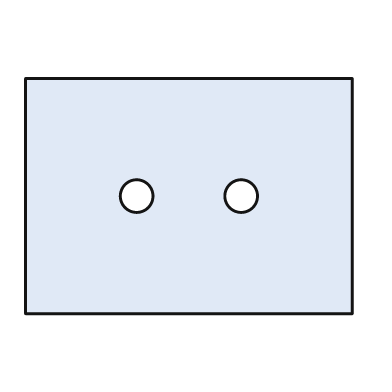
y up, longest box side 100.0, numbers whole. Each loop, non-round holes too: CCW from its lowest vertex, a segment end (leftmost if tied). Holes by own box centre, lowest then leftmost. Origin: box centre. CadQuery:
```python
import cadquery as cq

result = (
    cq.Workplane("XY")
    .moveTo(-50.0, -36.0)
    .lineTo(50.0, -36.0)
    .lineTo(50.0, 36.0)
    .lineTo(-50.0, 36.0)
    .close()
    .moveTo(-16.0, 0.0)
    .circle(5.0)
    .moveTo(16.0, 0.0)
    .circle(5.0)
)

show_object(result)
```